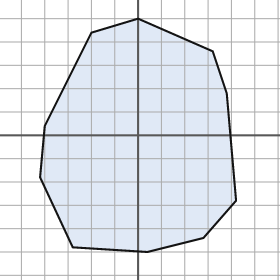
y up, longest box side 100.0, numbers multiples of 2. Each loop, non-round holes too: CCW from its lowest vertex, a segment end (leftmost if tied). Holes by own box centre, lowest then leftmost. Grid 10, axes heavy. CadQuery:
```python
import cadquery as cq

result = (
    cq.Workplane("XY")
    .moveTo(4.0, -50.0)
    .lineTo(28.0, -44.0)
    .lineTo(42.0, -28.0)
    .lineTo(38.0, 18.0)
    .lineTo(32.0, 36.0)
    .lineTo(0.0, 50.0)
    .lineTo(-20.0, 44.0)
    .lineTo(-40.0, 4.0)
    .lineTo(-42.0, -18.0)
    .lineTo(-28.0, -48.0)
    .close()
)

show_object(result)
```